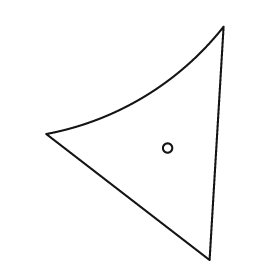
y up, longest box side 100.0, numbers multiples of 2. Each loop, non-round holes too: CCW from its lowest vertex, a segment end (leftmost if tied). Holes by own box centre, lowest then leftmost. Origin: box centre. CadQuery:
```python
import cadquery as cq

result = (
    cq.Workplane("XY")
    .moveTo(32.0, -50.0)
    .lineTo(38.0, 50.0)
    .threePointArc((4.0, 20.0), (-38.0, 4.0))
    .close()
    .moveTo(14.0, -2.0)
    .circle(2.0)
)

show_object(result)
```